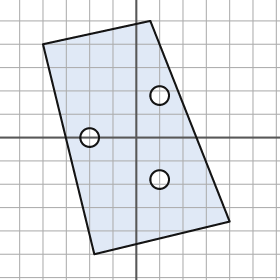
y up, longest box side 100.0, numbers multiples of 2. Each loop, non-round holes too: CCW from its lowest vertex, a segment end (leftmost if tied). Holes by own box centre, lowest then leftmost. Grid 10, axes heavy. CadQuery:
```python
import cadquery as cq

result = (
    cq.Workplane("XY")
    .moveTo(-18.0, -50.0)
    .lineTo(40.0, -36.0)
    .lineTo(6.0, 50.0)
    .lineTo(-40.0, 40.0)
    .close()
    .moveTo(10.0, -18.0)
    .circle(4.0)
    .moveTo(-20.0, 0.0)
    .circle(4.0)
    .moveTo(10.0, 18.0)
    .circle(4.0)
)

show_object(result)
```